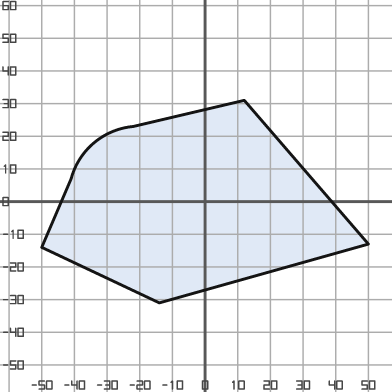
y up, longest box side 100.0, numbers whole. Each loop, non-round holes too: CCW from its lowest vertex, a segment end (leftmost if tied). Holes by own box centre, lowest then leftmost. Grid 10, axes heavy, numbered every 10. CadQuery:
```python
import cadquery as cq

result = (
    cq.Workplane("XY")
    .moveTo(-14.0, -31.0)
    .lineTo(50.0, -13.0)
    .lineTo(12.0, 31.0)
    .lineTo(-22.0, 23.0)
    .threePointArc((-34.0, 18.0), (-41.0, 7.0))
    .lineTo(-50.0, -14.0)
    .close()
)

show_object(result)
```